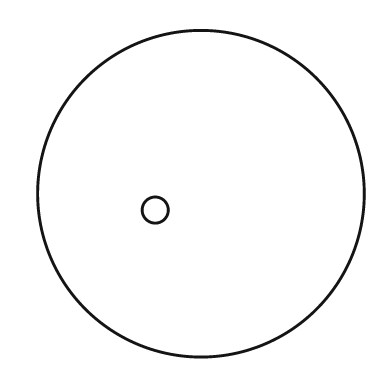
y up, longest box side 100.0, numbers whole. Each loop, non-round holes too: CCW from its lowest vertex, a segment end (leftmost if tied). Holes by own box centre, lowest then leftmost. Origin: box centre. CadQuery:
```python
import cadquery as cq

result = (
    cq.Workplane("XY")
    .moveTo(0.0, 0.0)
    .circle(50.0)
    .moveTo(-14.0, -5.0)
    .circle(4.0)
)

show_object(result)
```